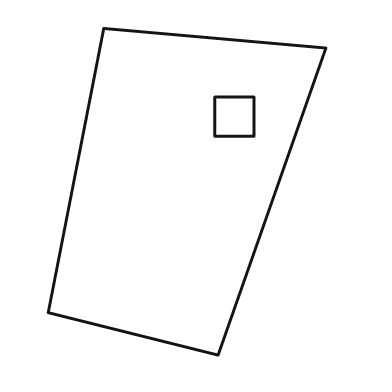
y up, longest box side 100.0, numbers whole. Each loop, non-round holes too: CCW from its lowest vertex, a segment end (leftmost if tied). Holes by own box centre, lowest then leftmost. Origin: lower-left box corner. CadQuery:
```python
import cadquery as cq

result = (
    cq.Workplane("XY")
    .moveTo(52.0, 0.0)
    .lineTo(85.0, 94.0)
    .lineTo(17.0, 100.0)
    .lineTo(0.0, 13.0)
    .close()
    .moveTo(51.0, 67.0)
    .lineTo(63.0, 67.0)
    .lineTo(63.0, 79.0)
    .lineTo(51.0, 79.0)
    .close()
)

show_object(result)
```